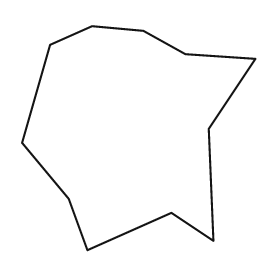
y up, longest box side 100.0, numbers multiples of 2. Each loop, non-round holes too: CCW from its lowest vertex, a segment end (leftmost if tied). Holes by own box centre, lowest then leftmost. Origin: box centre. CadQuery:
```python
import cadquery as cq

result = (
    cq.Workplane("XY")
    .moveTo(-22.0, -48.0)
    .lineTo(14.0, -32.0)
    .lineTo(32.0, -44.0)
    .lineTo(30.0, 4.0)
    .lineTo(50.0, 34.0)
    .lineTo(20.0, 36.0)
    .lineTo(2.0, 46.0)
    .lineTo(-20.0, 48.0)
    .lineTo(-38.0, 40.0)
    .lineTo(-50.0, -2.0)
    .lineTo(-30.0, -26.0)
    .close()
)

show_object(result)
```